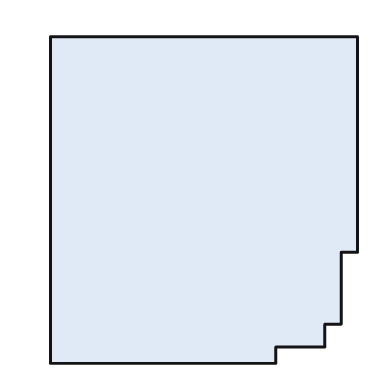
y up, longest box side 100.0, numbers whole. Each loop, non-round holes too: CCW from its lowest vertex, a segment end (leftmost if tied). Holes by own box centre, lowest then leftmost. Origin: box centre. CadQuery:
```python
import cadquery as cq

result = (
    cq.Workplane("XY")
    .moveTo(-47.0, -50.0)
    .lineTo(22.0, -50.0)
    .lineTo(22.0, -45.0)
    .lineTo(37.0, -45.0)
    .lineTo(37.0, -38.0)
    .lineTo(42.0, -38.0)
    .lineTo(42.0, -16.0)
    .lineTo(47.0, -16.0)
    .lineTo(47.0, 50.0)
    .lineTo(-47.0, 50.0)
    .close()
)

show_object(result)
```